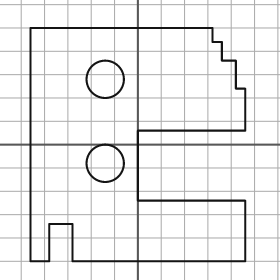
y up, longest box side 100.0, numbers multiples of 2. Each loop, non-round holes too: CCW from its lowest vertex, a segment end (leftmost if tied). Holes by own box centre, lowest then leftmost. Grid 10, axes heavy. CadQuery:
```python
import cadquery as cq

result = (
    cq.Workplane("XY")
    .moveTo(-46.0, -50.0)
    .lineTo(-38.0, -50.0)
    .lineTo(-38.0, -34.0)
    .lineTo(-28.0, -34.0)
    .lineTo(-28.0, -50.0)
    .lineTo(46.0, -50.0)
    .lineTo(46.0, -24.0)
    .lineTo(0.0, -24.0)
    .lineTo(0.0, 6.0)
    .lineTo(46.0, 6.0)
    .lineTo(46.0, 24.0)
    .lineTo(42.0, 24.0)
    .lineTo(42.0, 36.0)
    .lineTo(36.0, 36.0)
    .lineTo(36.0, 44.0)
    .lineTo(32.0, 44.0)
    .lineTo(32.0, 50.0)
    .lineTo(-46.0, 50.0)
    .close()
    .moveTo(-14.0, -8.0)
    .circle(8.0)
    .moveTo(-14.0, 28.0)
    .circle(8.0)
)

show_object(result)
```